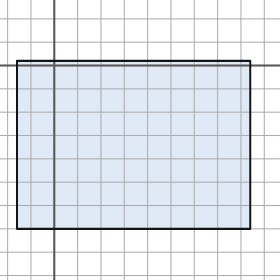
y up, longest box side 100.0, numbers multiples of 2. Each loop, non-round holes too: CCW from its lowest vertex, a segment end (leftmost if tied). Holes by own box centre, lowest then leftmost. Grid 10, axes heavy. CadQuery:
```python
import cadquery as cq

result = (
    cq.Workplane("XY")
    .moveTo(-16.0, -70.0)
    .lineTo(84.0, -70.0)
    .lineTo(84.0, 2.0)
    .lineTo(-16.0, 2.0)
    .close()
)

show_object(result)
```